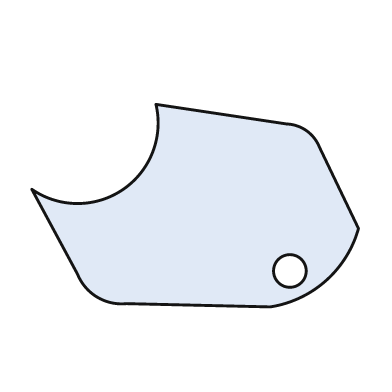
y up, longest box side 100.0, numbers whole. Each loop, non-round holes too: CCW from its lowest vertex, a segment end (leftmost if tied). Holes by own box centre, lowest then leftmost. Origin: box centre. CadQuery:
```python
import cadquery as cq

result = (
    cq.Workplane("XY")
    .moveTo(23.0, -31.0)
    .threePointArc((40.0, -23.0), (50.0, -7.0))
    .lineTo(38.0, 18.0)
    .threePointArc((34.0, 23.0), (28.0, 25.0))
    .lineTo(-12.0, 31.0)
    .threePointArc((-22.0, 5.0), (-50.0, 5.0))
    .lineTo(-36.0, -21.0)
    .threePointArc((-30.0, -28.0), (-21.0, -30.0))
    .close()
    .moveTo(29.0, -20.0)
    .circle(5.0)
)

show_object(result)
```